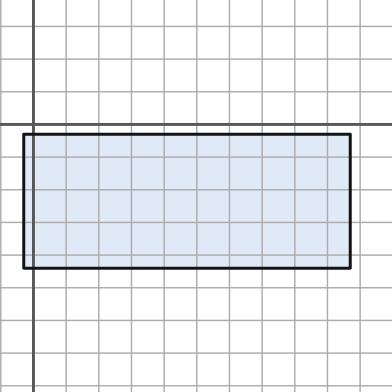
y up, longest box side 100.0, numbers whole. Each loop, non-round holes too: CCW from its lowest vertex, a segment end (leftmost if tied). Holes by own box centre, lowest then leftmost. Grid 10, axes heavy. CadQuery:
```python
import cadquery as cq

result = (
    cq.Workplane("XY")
    .moveTo(-3.0, -44.0)
    .lineTo(97.0, -44.0)
    .lineTo(97.0, -3.0)
    .lineTo(-3.0, -3.0)
    .close()
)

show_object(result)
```